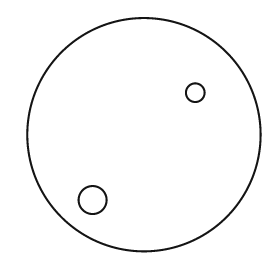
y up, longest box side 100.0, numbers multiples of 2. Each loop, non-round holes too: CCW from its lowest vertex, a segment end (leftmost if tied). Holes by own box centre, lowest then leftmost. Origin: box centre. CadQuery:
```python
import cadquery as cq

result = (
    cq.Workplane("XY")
    .moveTo(0.0, 0.0)
    .circle(50.0)
    .moveTo(-22.0, -28.0)
    .circle(6.0)
    .moveTo(22.0, 18.0)
    .circle(4.0)
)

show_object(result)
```